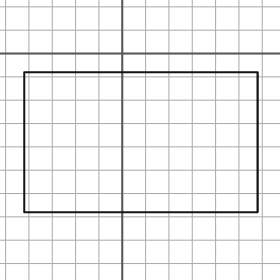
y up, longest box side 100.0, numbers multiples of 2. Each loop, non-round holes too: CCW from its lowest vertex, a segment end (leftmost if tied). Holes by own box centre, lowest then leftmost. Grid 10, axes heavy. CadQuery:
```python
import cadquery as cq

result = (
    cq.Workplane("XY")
    .moveTo(-42.0, -68.0)
    .lineTo(58.0, -68.0)
    .lineTo(58.0, -8.0)
    .lineTo(-42.0, -8.0)
    .close()
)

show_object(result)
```